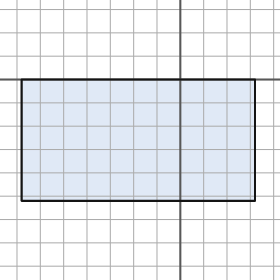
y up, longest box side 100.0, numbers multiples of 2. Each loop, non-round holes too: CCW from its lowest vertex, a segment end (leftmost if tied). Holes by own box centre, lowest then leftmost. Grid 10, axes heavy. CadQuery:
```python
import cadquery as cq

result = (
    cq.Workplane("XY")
    .moveTo(-68.0, -52.0)
    .lineTo(32.0, -52.0)
    .lineTo(32.0, 0.0)
    .lineTo(-68.0, 0.0)
    .close()
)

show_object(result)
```